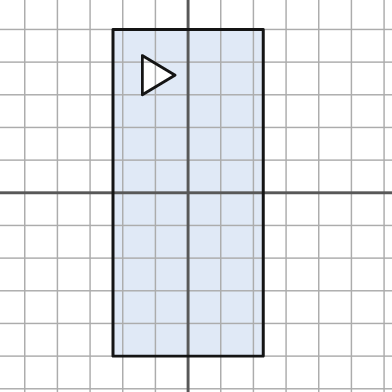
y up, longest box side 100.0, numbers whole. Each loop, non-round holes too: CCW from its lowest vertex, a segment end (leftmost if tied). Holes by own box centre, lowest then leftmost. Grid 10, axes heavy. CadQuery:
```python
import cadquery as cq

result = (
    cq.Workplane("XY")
    .moveTo(-23.0, -50.0)
    .lineTo(23.0, -50.0)
    .lineTo(23.0, 50.0)
    .lineTo(-23.0, 50.0)
    .close()
    .moveTo(-14.0, 30.0)
    .lineTo(-4.0, 36.0)
    .lineTo(-14.0, 42.0)
    .close()
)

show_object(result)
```